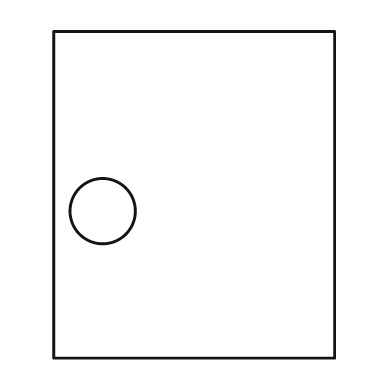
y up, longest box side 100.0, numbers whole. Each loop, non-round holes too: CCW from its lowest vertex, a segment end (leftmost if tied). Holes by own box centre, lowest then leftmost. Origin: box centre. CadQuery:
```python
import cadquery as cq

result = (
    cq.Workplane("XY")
    .moveTo(-43.0, -50.0)
    .lineTo(43.0, -50.0)
    .lineTo(43.0, 50.0)
    .lineTo(-43.0, 50.0)
    .close()
    .moveTo(-28.0, -5.0)
    .circle(10.0)
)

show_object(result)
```